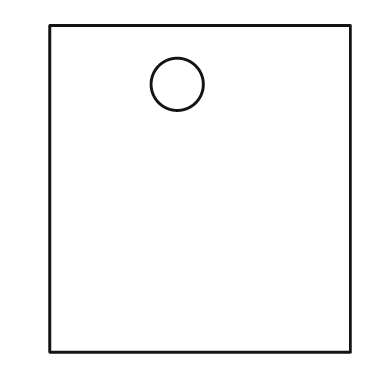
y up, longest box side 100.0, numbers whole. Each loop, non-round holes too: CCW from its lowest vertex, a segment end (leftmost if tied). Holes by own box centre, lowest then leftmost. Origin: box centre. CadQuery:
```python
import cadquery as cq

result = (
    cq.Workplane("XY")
    .moveTo(-46.0, -50.0)
    .lineTo(46.0, -50.0)
    .lineTo(46.0, 50.0)
    .lineTo(-46.0, 50.0)
    .close()
    .moveTo(-7.0, 32.0)
    .circle(8.0)
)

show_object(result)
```